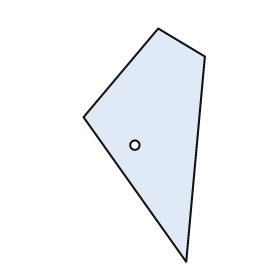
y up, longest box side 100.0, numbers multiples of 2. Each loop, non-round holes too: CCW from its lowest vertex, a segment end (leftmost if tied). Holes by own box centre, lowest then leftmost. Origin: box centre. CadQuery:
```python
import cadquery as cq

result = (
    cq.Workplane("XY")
    .moveTo(18.0, -50.0)
    .lineTo(26.0, 38.0)
    .lineTo(6.0, 50.0)
    .lineTo(-26.0, 12.0)
    .close()
    .moveTo(-4.0, 0.0)
    .circle(2.0)
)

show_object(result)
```